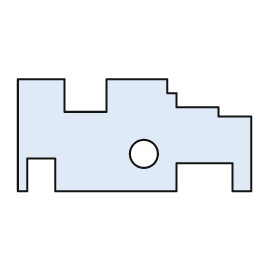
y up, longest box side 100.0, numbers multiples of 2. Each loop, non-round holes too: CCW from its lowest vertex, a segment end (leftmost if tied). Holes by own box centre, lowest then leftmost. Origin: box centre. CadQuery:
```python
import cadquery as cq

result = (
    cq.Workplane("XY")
    .moveTo(-50.0, -24.0)
    .lineTo(-46.0, -24.0)
    .lineTo(-46.0, -10.0)
    .lineTo(-34.0, -10.0)
    .lineTo(-34.0, -24.0)
    .lineTo(18.0, -24.0)
    .lineTo(18.0, -12.0)
    .lineTo(42.0, -12.0)
    .lineTo(42.0, -24.0)
    .lineTo(50.0, -24.0)
    .lineTo(50.0, 8.0)
    .lineTo(36.0, 8.0)
    .lineTo(36.0, 12.0)
    .lineTo(18.0, 12.0)
    .lineTo(18.0, 18.0)
    .lineTo(14.0, 18.0)
    .lineTo(14.0, 24.0)
    .lineTo(-12.0, 24.0)
    .lineTo(-12.0, 10.0)
    .lineTo(-30.0, 10.0)
    .lineTo(-30.0, 24.0)
    .lineTo(-50.0, 24.0)
    .close()
    .moveTo(4.0, -8.0)
    .circle(6.0)
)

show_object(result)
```